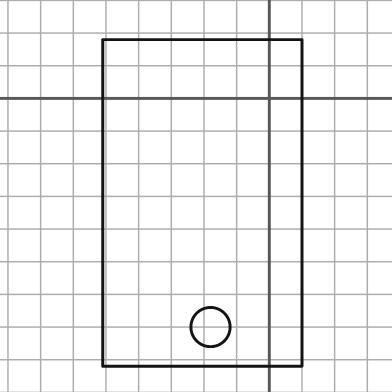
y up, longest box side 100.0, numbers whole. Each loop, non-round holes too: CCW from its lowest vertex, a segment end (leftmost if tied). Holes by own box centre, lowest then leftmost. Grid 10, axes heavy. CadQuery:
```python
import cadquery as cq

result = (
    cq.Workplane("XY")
    .moveTo(-51.0, -82.0)
    .lineTo(10.0, -82.0)
    .lineTo(10.0, 18.0)
    .lineTo(-51.0, 18.0)
    .close()
    .moveTo(-18.0, -70.0)
    .circle(6.0)
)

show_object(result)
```